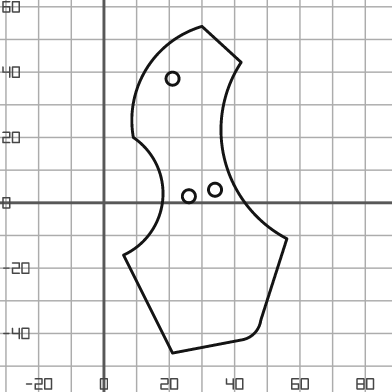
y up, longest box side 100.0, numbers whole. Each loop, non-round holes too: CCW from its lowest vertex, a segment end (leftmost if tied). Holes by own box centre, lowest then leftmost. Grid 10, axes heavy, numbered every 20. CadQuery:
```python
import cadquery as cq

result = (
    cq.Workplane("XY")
    .moveTo(21.0, -46.0)
    .lineTo(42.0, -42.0)
    .threePointArc((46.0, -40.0), (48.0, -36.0))
    .lineTo(56.0, -11.0)
    .threePointArc((37.0, 13.0), (42.0, 43.0))
    .lineTo(30.0, 54.0)
    .threePointArc((13.0, 41.0), (9.0, 20.0))
    .threePointArc((18.0, 1.0), (6.0, -16.0))
    .close()
    .moveTo(26.0, 2.0)
    .circle(2.0)
    .moveTo(34.0, 4.0)
    .circle(2.0)
    .moveTo(21.0, 38.0)
    .circle(2.0)
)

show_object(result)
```